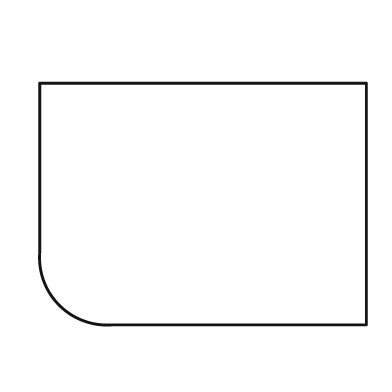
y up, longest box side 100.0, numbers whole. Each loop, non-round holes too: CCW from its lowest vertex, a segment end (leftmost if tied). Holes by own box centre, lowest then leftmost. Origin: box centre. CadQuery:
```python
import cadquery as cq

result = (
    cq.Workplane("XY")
    .moveTo(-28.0, -37.0)
    .lineTo(50.0, -37.0)
    .lineTo(50.0, 37.0)
    .lineTo(-50.0, 37.0)
    .lineTo(-50.0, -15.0)
    .threePointArc((-44.0, -31.0), (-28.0, -37.0))
    .close()
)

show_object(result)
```